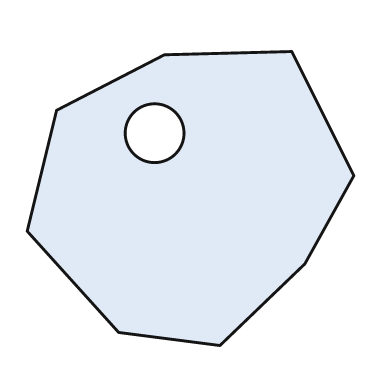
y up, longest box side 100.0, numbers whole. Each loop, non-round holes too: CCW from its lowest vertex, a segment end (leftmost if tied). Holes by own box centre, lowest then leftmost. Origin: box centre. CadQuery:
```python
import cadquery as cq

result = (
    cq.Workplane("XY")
    .moveTo(9.0, -45.0)
    .lineTo(35.0, -20.0)
    .lineTo(50.0, 7.0)
    .lineTo(31.0, 45.0)
    .lineTo(-8.0, 44.0)
    .lineTo(-41.0, 27.0)
    .lineTo(-50.0, -10.0)
    .lineTo(-22.0, -41.0)
    .close()
    .moveTo(-11.0, 20.0)
    .circle(9.0)
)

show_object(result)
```